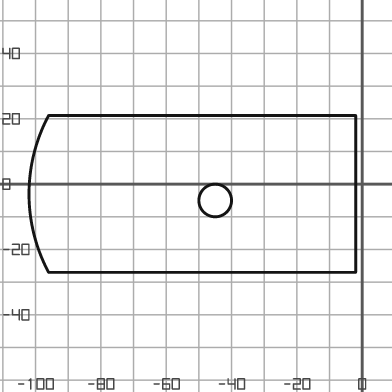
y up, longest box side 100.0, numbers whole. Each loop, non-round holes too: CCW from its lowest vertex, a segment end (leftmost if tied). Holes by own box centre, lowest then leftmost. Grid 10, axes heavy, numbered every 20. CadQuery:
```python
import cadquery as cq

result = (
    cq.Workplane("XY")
    .moveTo(-96.0, -27.0)
    .lineTo(-2.0, -27.0)
    .lineTo(-2.0, 21.0)
    .lineTo(-96.0, 21.0)
    .threePointArc((-102.0, -3.0), (-96.0, -27.0))
    .close()
    .moveTo(-45.0, -5.0)
    .circle(5.0)
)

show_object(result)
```